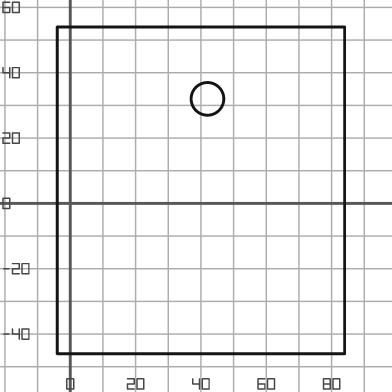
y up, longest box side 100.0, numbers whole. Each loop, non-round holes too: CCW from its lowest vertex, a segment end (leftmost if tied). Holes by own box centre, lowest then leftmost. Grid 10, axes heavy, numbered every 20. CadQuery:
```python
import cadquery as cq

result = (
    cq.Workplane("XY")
    .moveTo(-4.0, -46.0)
    .lineTo(84.0, -46.0)
    .lineTo(84.0, 54.0)
    .lineTo(-4.0, 54.0)
    .close()
    .moveTo(42.0, 32.0)
    .circle(5.0)
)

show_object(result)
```